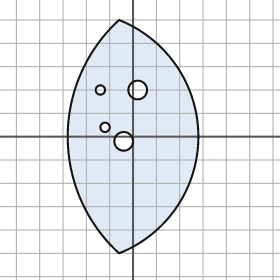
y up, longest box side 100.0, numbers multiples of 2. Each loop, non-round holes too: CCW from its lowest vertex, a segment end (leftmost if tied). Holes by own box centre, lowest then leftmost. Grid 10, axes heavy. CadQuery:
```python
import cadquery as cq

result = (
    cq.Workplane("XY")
    .moveTo(-6.0, -50.0)
    .threePointArc((28.0, 0.0), (-6.0, 50.0))
    .threePointArc((-28.0, 0.0), (-6.0, -50.0))
    .close()
    .moveTo(-4.0, -2.0)
    .circle(4.0)
    .moveTo(-12.0, 4.0)
    .circle(2.0)
    .moveTo(-14.0, 20.0)
    .circle(2.0)
    .moveTo(2.0, 20.0)
    .circle(4.0)
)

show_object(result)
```